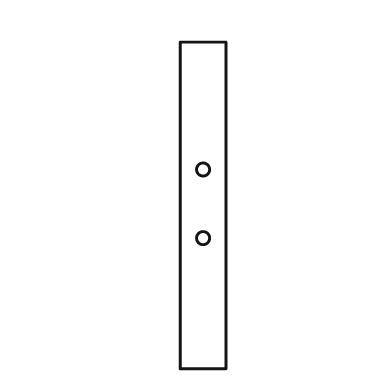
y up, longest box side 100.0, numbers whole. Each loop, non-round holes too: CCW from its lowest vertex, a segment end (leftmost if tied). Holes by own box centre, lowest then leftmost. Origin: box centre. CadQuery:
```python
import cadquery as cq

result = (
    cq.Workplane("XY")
    .moveTo(-7.0, -50.0)
    .lineTo(7.0, -50.0)
    .lineTo(7.0, 50.0)
    .lineTo(-7.0, 50.0)
    .close()
    .moveTo(0.0, -10.0)
    .circle(2.0)
    .moveTo(0.0, 11.0)
    .circle(2.0)
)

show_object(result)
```